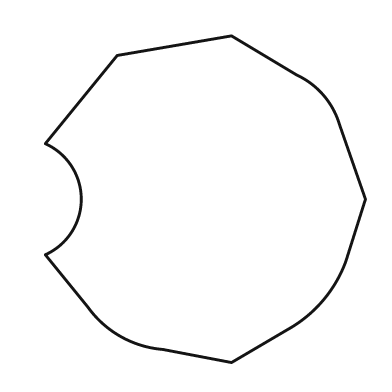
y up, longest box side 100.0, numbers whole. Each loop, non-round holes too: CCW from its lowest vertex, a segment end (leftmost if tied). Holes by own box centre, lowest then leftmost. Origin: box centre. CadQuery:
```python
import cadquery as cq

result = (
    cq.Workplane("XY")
    .moveTo(8.0, -50.0)
    .lineTo(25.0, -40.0)
    .threePointArc((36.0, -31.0), (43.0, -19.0))
    .lineTo(49.0, 0.0)
    .lineTo(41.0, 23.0)
    .threePointArc((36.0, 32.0), (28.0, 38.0))
    .lineTo(8.0, 50.0)
    .lineTo(-27.0, 44.0)
    .lineTo(-49.0, 17.0)
    .threePointArc((-38.0, 0.0), (-49.0, -17.0))
    .lineTo(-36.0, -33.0)
    .threePointArc((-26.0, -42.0), (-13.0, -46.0))
    .close()
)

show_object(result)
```